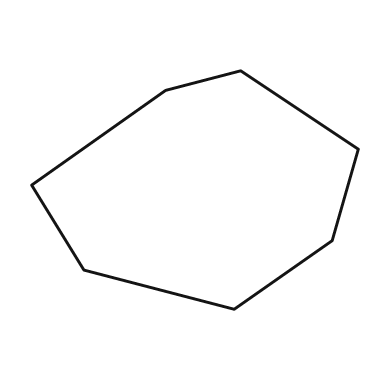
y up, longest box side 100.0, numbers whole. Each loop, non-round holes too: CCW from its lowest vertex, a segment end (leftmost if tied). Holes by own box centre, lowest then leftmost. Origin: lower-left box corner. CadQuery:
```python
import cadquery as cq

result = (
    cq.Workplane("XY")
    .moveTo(62.0, 0.0)
    .lineTo(92.0, 21.0)
    .lineTo(100.0, 49.0)
    .lineTo(64.0, 73.0)
    .lineTo(41.0, 67.0)
    .lineTo(0.0, 38.0)
    .lineTo(16.0, 12.0)
    .close()
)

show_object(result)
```